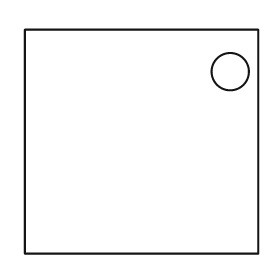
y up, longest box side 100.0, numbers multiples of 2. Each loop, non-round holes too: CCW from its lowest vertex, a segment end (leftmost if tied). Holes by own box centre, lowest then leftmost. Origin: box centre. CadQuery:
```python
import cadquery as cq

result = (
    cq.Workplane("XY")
    .moveTo(-50.0, -48.0)
    .lineTo(50.0, -48.0)
    .lineTo(50.0, 48.0)
    .lineTo(-50.0, 48.0)
    .close()
    .moveTo(38.0, 30.0)
    .circle(8.0)
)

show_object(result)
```